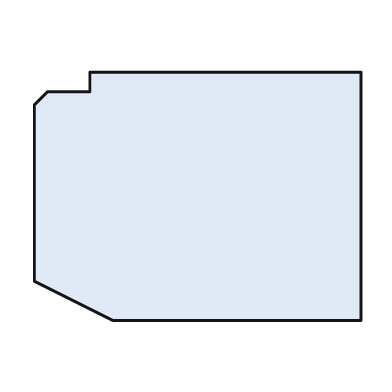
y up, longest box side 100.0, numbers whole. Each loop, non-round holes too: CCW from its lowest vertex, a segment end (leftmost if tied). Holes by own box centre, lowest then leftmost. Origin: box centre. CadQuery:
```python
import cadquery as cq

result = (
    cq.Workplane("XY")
    .moveTo(-26.0, -38.0)
    .lineTo(50.0, -38.0)
    .lineTo(50.0, 38.0)
    .lineTo(-33.0, 38.0)
    .lineTo(-33.0, 32.0)
    .lineTo(-46.0, 32.0)
    .lineTo(-50.0, 28.0)
    .lineTo(-50.0, -26.0)
    .close()
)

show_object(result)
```